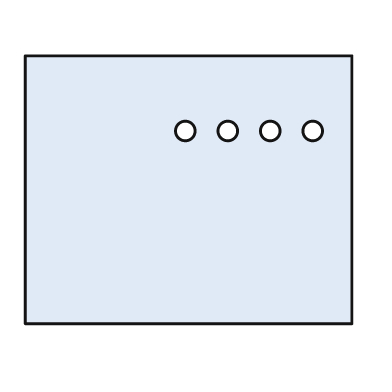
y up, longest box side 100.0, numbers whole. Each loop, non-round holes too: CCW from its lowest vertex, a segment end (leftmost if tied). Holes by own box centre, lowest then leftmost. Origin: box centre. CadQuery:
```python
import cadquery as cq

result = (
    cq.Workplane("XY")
    .moveTo(-50.0, -41.0)
    .lineTo(50.0, -41.0)
    .lineTo(50.0, 41.0)
    .lineTo(-50.0, 41.0)
    .close()
    .moveTo(-1.0, 18.0)
    .circle(3.0)
    .moveTo(12.0, 18.0)
    .circle(3.0)
    .moveTo(25.0, 18.0)
    .circle(3.0)
    .moveTo(38.0, 18.0)
    .circle(3.0)
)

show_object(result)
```